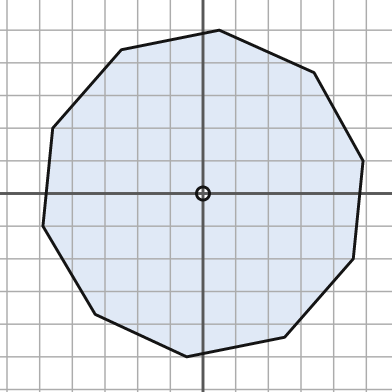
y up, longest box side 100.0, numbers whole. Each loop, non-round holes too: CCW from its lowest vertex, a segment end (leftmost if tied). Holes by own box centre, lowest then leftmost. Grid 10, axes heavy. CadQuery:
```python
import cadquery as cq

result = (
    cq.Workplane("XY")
    .moveTo(-5.0, -50.0)
    .lineTo(25.0, -44.0)
    .lineTo(46.0, -20.0)
    .lineTo(49.0, 10.0)
    .lineTo(34.0, 37.0)
    .lineTo(5.0, 50.0)
    .lineTo(-25.0, 44.0)
    .lineTo(-46.0, 20.0)
    .lineTo(-49.0, -10.0)
    .lineTo(-33.0, -37.0)
    .close()
    .moveTo(0.0, 0.0)
    .circle(2.0)
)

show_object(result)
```